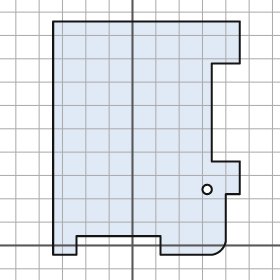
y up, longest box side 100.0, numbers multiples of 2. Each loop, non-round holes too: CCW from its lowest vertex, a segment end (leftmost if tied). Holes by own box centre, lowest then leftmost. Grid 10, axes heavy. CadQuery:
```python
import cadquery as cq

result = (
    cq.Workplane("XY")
    .moveTo(-34.0, -4.0)
    .lineTo(-24.0, -4.0)
    .lineTo(-24.0, 4.0)
    .lineTo(12.0, 4.0)
    .lineTo(12.0, -4.0)
    .lineTo(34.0, -4.0)
    .threePointArc((38.0, -2.0), (40.0, 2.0))
    .lineTo(40.0, 22.0)
    .lineTo(46.0, 22.0)
    .lineTo(46.0, 36.0)
    .lineTo(34.0, 36.0)
    .lineTo(34.0, 78.0)
    .lineTo(46.0, 78.0)
    .lineTo(46.0, 96.0)
    .lineTo(-34.0, 96.0)
    .close()
    .moveTo(32.0, 24.0)
    .circle(2.0)
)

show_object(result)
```